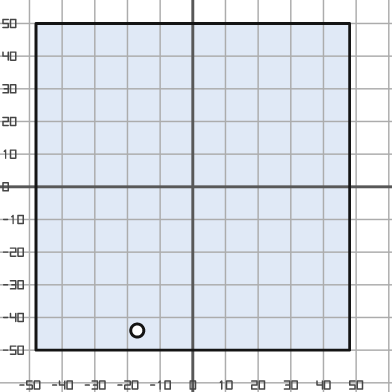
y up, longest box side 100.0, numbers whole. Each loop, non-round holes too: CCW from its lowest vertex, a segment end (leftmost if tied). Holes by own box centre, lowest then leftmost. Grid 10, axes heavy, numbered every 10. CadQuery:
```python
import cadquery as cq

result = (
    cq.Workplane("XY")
    .moveTo(-48.0, -50.0)
    .lineTo(48.0, -50.0)
    .lineTo(48.0, 50.0)
    .lineTo(-48.0, 50.0)
    .close()
    .moveTo(-17.0, -44.0)
    .circle(2.0)
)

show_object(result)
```